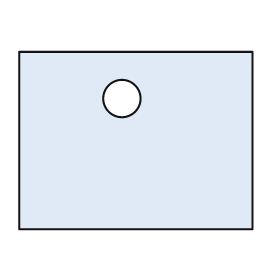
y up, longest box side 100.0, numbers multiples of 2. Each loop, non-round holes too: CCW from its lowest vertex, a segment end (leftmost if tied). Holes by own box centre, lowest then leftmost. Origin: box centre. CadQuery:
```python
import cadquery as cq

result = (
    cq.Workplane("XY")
    .moveTo(-50.0, -38.0)
    .lineTo(50.0, -38.0)
    .lineTo(50.0, 38.0)
    .lineTo(-50.0, 38.0)
    .close()
    .moveTo(-6.0, 18.0)
    .circle(8.0)
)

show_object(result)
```